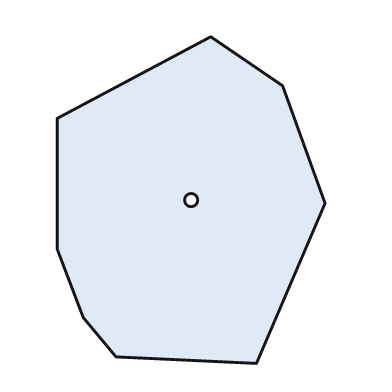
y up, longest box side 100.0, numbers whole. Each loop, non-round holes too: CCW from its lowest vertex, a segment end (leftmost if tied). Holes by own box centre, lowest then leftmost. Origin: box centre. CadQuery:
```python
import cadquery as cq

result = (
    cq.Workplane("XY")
    .moveTo(20.0, -50.0)
    .lineTo(41.0, -1.0)
    .lineTo(28.0, 35.0)
    .lineTo(6.0, 50.0)
    .lineTo(-41.0, 25.0)
    .lineTo(-41.0, -15.0)
    .lineTo(-33.0, -36.0)
    .lineTo(-23.0, -48.0)
    .close()
    .moveTo(0.0, 0.0)
    .circle(2.0)
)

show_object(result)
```